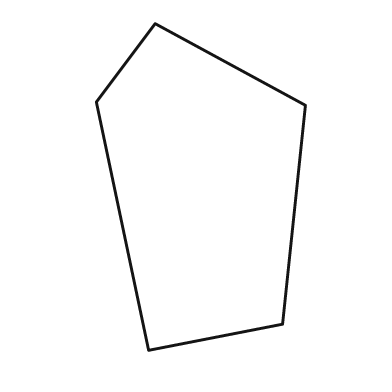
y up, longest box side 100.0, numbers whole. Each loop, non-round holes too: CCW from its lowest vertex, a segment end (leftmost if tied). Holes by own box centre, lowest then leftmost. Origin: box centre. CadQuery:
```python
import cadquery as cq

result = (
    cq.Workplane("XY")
    .moveTo(-16.0, -50.0)
    .lineTo(25.0, -42.0)
    .lineTo(32.0, 25.0)
    .lineTo(-14.0, 50.0)
    .lineTo(-32.0, 26.0)
    .close()
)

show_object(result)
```